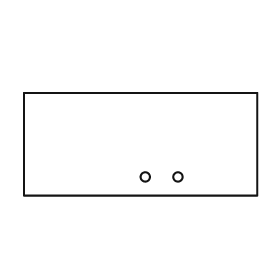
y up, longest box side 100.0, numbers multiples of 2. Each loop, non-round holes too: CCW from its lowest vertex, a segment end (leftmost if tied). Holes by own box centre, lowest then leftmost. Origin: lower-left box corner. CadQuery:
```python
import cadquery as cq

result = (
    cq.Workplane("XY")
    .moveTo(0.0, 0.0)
    .lineTo(100.0, 0.0)
    .lineTo(100.0, 44.0)
    .lineTo(0.0, 44.0)
    .close()
    .moveTo(52.0, 8.0)
    .circle(2.0)
    .moveTo(66.0, 8.0)
    .circle(2.0)
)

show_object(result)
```